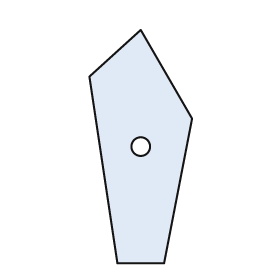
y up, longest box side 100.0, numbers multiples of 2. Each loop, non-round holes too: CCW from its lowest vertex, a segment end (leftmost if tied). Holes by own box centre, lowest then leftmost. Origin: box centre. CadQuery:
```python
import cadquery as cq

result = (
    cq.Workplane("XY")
    .moveTo(-10.0, -50.0)
    .lineTo(10.0, -50.0)
    .lineTo(22.0, 12.0)
    .lineTo(0.0, 50.0)
    .lineTo(-22.0, 30.0)
    .close()
    .moveTo(0.0, 0.0)
    .circle(4.0)
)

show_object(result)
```